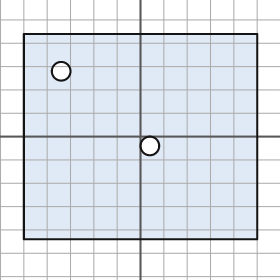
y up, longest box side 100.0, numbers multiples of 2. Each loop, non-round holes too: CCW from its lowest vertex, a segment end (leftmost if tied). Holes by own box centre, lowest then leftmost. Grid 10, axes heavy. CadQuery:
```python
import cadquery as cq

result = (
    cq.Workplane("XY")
    .moveTo(-50.0, -44.0)
    .lineTo(50.0, -44.0)
    .lineTo(50.0, 44.0)
    .lineTo(-50.0, 44.0)
    .close()
    .moveTo(4.0, -4.0)
    .circle(4.0)
    .moveTo(-34.0, 28.0)
    .circle(4.0)
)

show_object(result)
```